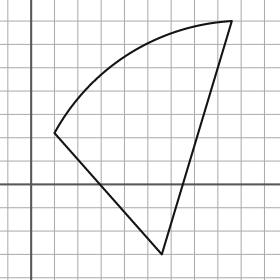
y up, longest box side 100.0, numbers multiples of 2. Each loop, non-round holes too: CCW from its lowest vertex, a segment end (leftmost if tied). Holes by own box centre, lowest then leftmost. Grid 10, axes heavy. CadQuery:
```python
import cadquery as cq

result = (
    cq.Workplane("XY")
    .moveTo(56.0, -30.0)
    .lineTo(86.0, 70.0)
    .threePointArc((42.0, 56.0), (10.0, 22.0))
    .close()
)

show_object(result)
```